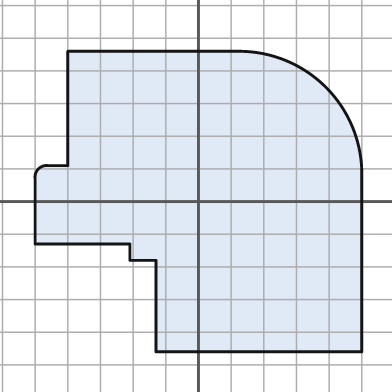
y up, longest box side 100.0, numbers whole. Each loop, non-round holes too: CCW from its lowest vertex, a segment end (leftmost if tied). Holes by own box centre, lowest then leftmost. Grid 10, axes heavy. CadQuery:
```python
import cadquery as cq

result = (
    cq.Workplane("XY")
    .moveTo(-13.0, -46.0)
    .lineTo(50.0, -46.0)
    .lineTo(50.0, 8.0)
    .threePointArc((39.0, 35.0), (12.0, 46.0))
    .lineTo(-40.0, 46.0)
    .lineTo(-40.0, 11.0)
    .lineTo(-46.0, 11.0)
    .threePointArc((-49.0, 10.0), (-50.0, 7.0))
    .lineTo(-50.0, -13.0)
    .lineTo(-21.0, -13.0)
    .lineTo(-21.0, -18.0)
    .lineTo(-13.0, -18.0)
    .close()
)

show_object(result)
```